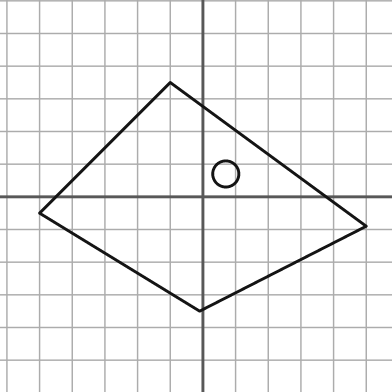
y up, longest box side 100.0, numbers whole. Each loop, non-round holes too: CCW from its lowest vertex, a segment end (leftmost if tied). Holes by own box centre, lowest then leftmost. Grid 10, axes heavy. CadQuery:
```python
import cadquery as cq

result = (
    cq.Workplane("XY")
    .moveTo(-1.0, -35.0)
    .lineTo(50.0, -9.0)
    .lineTo(-10.0, 35.0)
    .lineTo(-50.0, -5.0)
    .close()
    .moveTo(7.0, 7.0)
    .circle(4.0)
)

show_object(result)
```